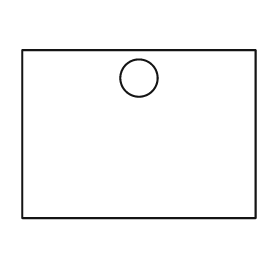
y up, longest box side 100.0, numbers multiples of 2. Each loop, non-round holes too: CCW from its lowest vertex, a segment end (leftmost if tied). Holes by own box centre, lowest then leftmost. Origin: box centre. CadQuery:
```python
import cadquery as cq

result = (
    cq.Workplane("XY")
    .moveTo(-50.0, -36.0)
    .lineTo(50.0, -36.0)
    .lineTo(50.0, 36.0)
    .lineTo(-50.0, 36.0)
    .close()
    .moveTo(0.0, 24.0)
    .circle(8.0)
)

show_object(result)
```